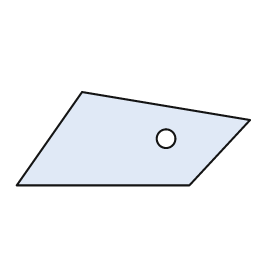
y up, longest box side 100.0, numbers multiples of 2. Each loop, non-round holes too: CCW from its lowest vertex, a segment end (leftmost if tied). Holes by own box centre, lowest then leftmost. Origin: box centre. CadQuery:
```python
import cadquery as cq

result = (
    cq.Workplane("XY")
    .moveTo(-50.0, -20.0)
    .lineTo(24.0, -20.0)
    .lineTo(50.0, 8.0)
    .lineTo(-22.0, 20.0)
    .close()
    .moveTo(14.0, 0.0)
    .circle(4.0)
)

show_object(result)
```